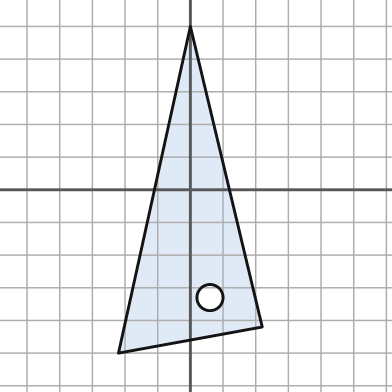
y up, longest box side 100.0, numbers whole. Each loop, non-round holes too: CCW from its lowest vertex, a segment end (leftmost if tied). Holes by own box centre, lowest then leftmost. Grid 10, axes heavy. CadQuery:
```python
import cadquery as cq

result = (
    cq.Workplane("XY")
    .moveTo(-22.0, -50.0)
    .lineTo(22.0, -42.0)
    .lineTo(0.0, 50.0)
    .close()
    .moveTo(6.0, -33.0)
    .circle(4.0)
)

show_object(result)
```